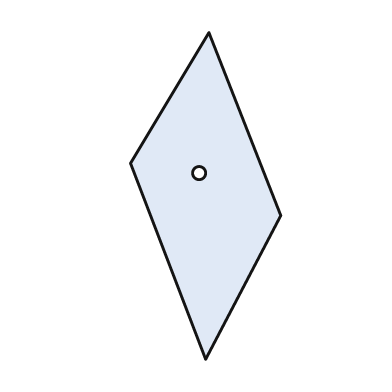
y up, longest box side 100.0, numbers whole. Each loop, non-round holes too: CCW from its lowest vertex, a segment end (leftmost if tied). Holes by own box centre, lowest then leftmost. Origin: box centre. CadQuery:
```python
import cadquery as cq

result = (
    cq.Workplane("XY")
    .moveTo(0.0, -50.0)
    .lineTo(23.0, -6.0)
    .lineTo(1.0, 50.0)
    .lineTo(-23.0, 10.0)
    .close()
    .moveTo(-2.0, 7.0)
    .circle(2.0)
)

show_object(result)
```